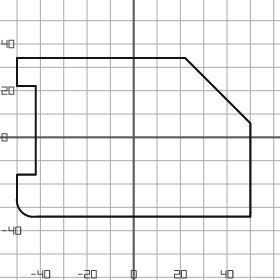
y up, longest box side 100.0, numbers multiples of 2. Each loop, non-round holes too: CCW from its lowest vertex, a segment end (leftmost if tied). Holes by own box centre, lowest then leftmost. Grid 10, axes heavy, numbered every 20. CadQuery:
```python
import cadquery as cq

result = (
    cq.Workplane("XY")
    .moveTo(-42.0, -34.0)
    .lineTo(50.0, -34.0)
    .lineTo(50.0, 6.0)
    .lineTo(22.0, 34.0)
    .lineTo(-50.0, 34.0)
    .lineTo(-50.0, 22.0)
    .lineTo(-42.0, 22.0)
    .lineTo(-42.0, -16.0)
    .lineTo(-50.0, -16.0)
    .lineTo(-50.0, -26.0)
    .threePointArc((-48.0, -32.0), (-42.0, -34.0))
    .close()
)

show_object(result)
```